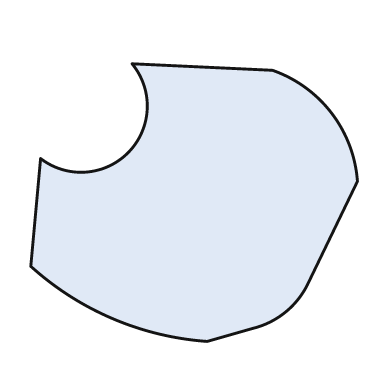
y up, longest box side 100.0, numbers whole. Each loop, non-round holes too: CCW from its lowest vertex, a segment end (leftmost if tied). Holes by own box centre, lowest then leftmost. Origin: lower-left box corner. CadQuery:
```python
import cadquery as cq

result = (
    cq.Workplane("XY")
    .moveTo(54.0, 0.0)
    .lineTo(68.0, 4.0)
    .threePointArc((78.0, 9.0), (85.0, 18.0))
    .lineTo(100.0, 49.0)
    .threePointArc((92.0, 70.0), (74.0, 83.0))
    .lineTo(31.0, 85.0)
    .threePointArc((30.0, 58.0), (3.0, 56.0))
    .lineTo(0.0, 23.0)
    .threePointArc((25.0, 7.0), (54.0, 0.0))
    .close()
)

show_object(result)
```